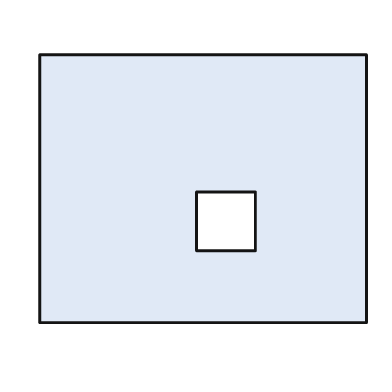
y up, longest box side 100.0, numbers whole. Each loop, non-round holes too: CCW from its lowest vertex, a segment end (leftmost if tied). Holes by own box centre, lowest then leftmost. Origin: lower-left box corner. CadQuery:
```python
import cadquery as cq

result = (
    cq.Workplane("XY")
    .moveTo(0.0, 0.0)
    .lineTo(100.0, 0.0)
    .lineTo(100.0, 82.0)
    .lineTo(0.0, 82.0)
    .close()
    .moveTo(48.0, 22.0)
    .lineTo(66.0, 22.0)
    .lineTo(66.0, 40.0)
    .lineTo(48.0, 40.0)
    .close()
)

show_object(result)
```